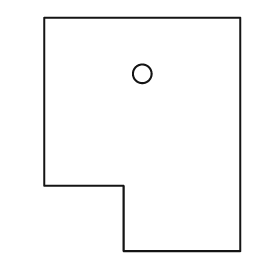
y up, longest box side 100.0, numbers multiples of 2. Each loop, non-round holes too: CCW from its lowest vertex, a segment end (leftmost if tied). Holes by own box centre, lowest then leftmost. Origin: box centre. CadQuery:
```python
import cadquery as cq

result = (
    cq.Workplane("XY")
    .moveTo(-8.0, -50.0)
    .lineTo(42.0, -50.0)
    .lineTo(42.0, 50.0)
    .lineTo(-42.0, 50.0)
    .lineTo(-42.0, -22.0)
    .lineTo(-8.0, -22.0)
    .close()
    .moveTo(0.0, 26.0)
    .circle(4.0)
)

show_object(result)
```